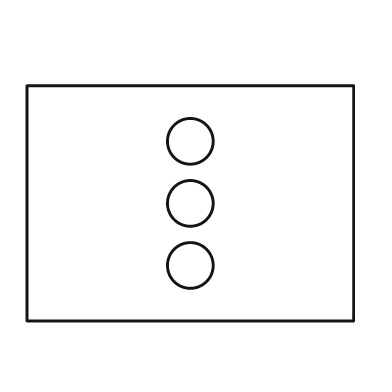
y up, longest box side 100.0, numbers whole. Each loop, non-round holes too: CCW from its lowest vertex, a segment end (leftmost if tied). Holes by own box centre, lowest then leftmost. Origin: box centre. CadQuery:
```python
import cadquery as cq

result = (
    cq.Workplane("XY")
    .moveTo(-50.0, -36.0)
    .lineTo(50.0, -36.0)
    .lineTo(50.0, 36.0)
    .lineTo(-50.0, 36.0)
    .close()
    .moveTo(0.0, -19.0)
    .circle(7.0)
    .moveTo(0.0, 0.0)
    .circle(7.0)
    .moveTo(0.0, 19.0)
    .circle(7.0)
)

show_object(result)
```